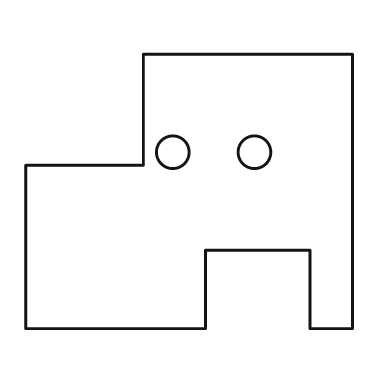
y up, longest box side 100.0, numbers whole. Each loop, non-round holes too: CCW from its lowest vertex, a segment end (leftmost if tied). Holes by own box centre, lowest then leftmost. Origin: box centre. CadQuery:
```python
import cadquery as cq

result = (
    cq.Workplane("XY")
    .moveTo(-50.0, -42.0)
    .lineTo(5.0, -42.0)
    .lineTo(5.0, -18.0)
    .lineTo(37.0, -18.0)
    .lineTo(37.0, -42.0)
    .lineTo(50.0, -42.0)
    .lineTo(50.0, 42.0)
    .lineTo(-14.0, 42.0)
    .lineTo(-14.0, 8.0)
    .lineTo(-50.0, 8.0)
    .close()
    .moveTo(-5.0, 12.0)
    .circle(5.0)
    .moveTo(20.0, 12.0)
    .circle(5.0)
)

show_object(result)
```